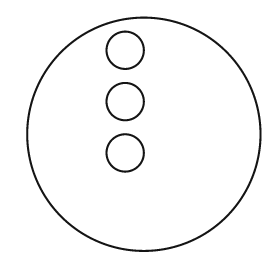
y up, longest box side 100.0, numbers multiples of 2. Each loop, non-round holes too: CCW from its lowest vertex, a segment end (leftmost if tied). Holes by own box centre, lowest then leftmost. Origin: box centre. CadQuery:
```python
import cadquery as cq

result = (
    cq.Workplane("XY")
    .moveTo(0.0, 0.0)
    .circle(50.0)
    .moveTo(-8.0, -8.0)
    .circle(8.0)
    .moveTo(-8.0, 14.0)
    .circle(8.0)
    .moveTo(-8.0, 36.0)
    .circle(8.0)
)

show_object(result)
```